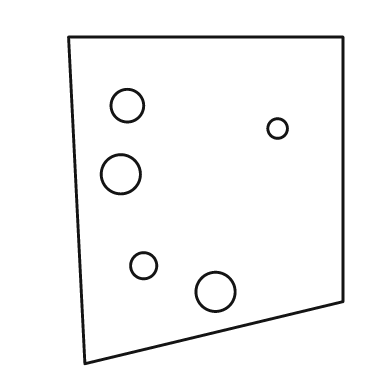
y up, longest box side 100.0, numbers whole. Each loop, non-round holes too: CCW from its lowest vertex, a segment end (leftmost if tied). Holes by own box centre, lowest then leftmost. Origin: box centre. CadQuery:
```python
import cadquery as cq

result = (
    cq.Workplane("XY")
    .moveTo(-37.0, -50.0)
    .lineTo(42.0, -31.0)
    .lineTo(42.0, 50.0)
    .lineTo(-42.0, 50.0)
    .close()
    .moveTo(3.0, -28.0)
    .circle(6.0)
    .moveTo(-19.0, -20.0)
    .circle(4.0)
    .moveTo(-26.0, 8.0)
    .circle(6.0)
    .moveTo(22.0, 22.0)
    .circle(3.0)
    .moveTo(-24.0, 29.0)
    .circle(5.0)
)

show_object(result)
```